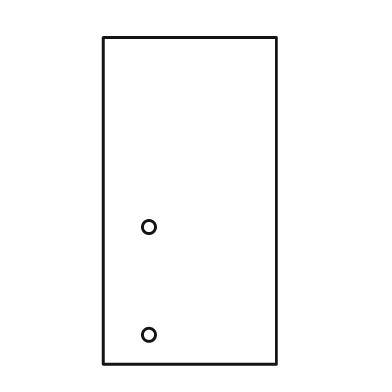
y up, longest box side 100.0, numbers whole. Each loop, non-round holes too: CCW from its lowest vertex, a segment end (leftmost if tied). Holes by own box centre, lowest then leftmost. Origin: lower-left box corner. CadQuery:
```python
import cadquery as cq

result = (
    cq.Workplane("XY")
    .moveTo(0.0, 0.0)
    .lineTo(53.0, 0.0)
    .lineTo(53.0, 100.0)
    .lineTo(0.0, 100.0)
    .close()
    .moveTo(14.0, 9.0)
    .circle(2.0)
    .moveTo(14.0, 42.0)
    .circle(2.0)
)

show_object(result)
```